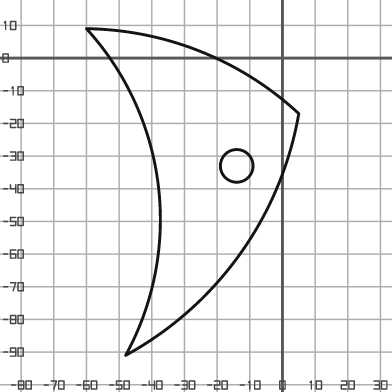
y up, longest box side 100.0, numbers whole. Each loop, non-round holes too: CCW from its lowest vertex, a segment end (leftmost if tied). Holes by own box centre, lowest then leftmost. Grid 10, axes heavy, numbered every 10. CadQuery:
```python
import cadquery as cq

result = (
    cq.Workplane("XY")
    .moveTo(-48.0, -91.0)
    .threePointArc((-13.0, -60.0), (5.0, -17.0))
    .threePointArc((-25.0, 2.0), (-60.0, 9.0))
    .threePointArc((-38.0, -39.0), (-48.0, -91.0))
    .close()
    .moveTo(-14.0, -33.0)
    .circle(5.0)
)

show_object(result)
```